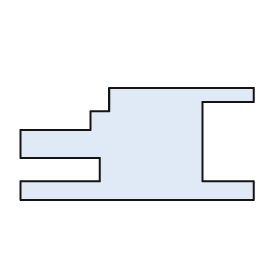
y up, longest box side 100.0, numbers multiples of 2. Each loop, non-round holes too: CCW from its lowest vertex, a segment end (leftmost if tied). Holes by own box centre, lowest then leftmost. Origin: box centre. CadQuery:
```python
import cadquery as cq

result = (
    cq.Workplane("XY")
    .moveTo(-50.0, -24.0)
    .lineTo(50.0, -24.0)
    .lineTo(50.0, -16.0)
    .lineTo(28.0, -16.0)
    .lineTo(28.0, 18.0)
    .lineTo(50.0, 18.0)
    .lineTo(50.0, 24.0)
    .lineTo(-12.0, 24.0)
    .lineTo(-12.0, 14.0)
    .lineTo(-20.0, 14.0)
    .lineTo(-20.0, 6.0)
    .lineTo(-50.0, 6.0)
    .lineTo(-50.0, -6.0)
    .lineTo(-16.0, -6.0)
    .lineTo(-16.0, -16.0)
    .lineTo(-50.0, -16.0)
    .close()
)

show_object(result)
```